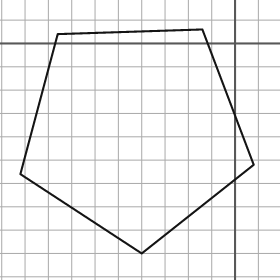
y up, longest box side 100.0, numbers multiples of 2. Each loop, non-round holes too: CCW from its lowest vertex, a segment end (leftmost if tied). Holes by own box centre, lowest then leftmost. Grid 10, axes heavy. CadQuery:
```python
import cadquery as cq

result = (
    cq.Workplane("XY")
    .moveTo(-40.0, -90.0)
    .lineTo(8.0, -52.0)
    .lineTo(-14.0, 6.0)
    .lineTo(-76.0, 4.0)
    .lineTo(-92.0, -56.0)
    .close()
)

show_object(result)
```